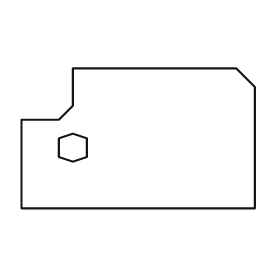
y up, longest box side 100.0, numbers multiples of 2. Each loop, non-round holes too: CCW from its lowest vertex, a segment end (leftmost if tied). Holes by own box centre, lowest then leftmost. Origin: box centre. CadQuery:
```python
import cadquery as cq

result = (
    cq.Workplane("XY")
    .moveTo(-50.0, -30.0)
    .lineTo(50.0, -30.0)
    .lineTo(50.0, 22.0)
    .lineTo(42.0, 30.0)
    .lineTo(-28.0, 30.0)
    .lineTo(-28.0, 14.0)
    .lineTo(-34.0, 8.0)
    .lineTo(-50.0, 8.0)
    .close()
    .moveTo(-28.0, -10.0)
    .lineTo(-22.0, -8.0)
    .lineTo(-22.0, 0.0)
    .lineTo(-28.0, 2.0)
    .lineTo(-34.0, 0.0)
    .lineTo(-34.0, -8.0)
    .close()
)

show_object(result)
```